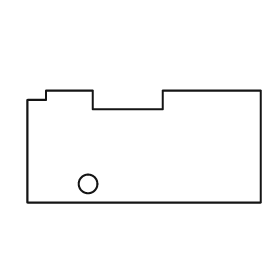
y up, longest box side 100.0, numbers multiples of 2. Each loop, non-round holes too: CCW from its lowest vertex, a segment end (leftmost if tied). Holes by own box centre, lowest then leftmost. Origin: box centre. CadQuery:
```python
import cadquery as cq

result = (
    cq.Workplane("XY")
    .moveTo(-50.0, -24.0)
    .lineTo(50.0, -24.0)
    .lineTo(50.0, 24.0)
    .lineTo(8.0, 24.0)
    .lineTo(8.0, 16.0)
    .lineTo(-22.0, 16.0)
    .lineTo(-22.0, 24.0)
    .lineTo(-42.0, 24.0)
    .lineTo(-42.0, 20.0)
    .lineTo(-50.0, 20.0)
    .close()
    .moveTo(-24.0, -16.0)
    .circle(4.0)
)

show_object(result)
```